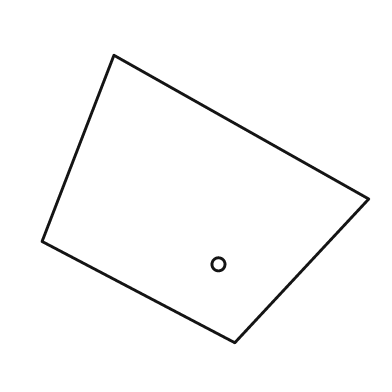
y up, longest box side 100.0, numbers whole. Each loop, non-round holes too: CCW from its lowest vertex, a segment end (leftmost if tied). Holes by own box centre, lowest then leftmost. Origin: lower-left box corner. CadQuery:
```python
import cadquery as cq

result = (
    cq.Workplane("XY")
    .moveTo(59.0, 0.0)
    .lineTo(100.0, 44.0)
    .lineTo(22.0, 88.0)
    .lineTo(0.0, 31.0)
    .close()
    .moveTo(54.0, 24.0)
    .circle(2.0)
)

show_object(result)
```